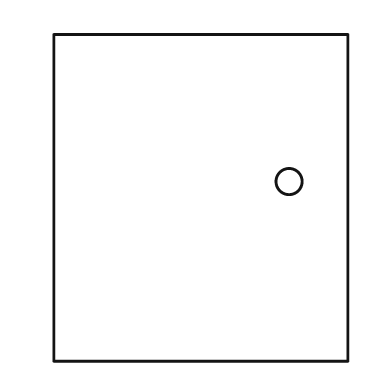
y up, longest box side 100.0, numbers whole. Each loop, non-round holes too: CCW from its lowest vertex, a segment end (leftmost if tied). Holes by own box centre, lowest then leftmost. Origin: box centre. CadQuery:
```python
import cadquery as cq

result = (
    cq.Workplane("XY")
    .moveTo(-45.0, -50.0)
    .lineTo(45.0, -50.0)
    .lineTo(45.0, 50.0)
    .lineTo(-45.0, 50.0)
    .close()
    .moveTo(27.0, 5.0)
    .circle(4.0)
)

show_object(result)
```